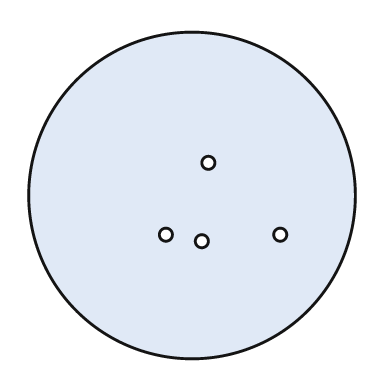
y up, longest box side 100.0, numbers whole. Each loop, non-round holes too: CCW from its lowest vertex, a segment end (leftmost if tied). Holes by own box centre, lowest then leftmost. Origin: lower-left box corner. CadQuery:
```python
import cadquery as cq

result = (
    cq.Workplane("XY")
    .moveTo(50.0, 50.0)
    .circle(50.0)
    .moveTo(53.0, 36.0)
    .circle(2.0)
    .moveTo(42.0, 38.0)
    .circle(2.0)
    .moveTo(77.0, 38.0)
    .circle(2.0)
    .moveTo(55.0, 60.0)
    .circle(2.0)
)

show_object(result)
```